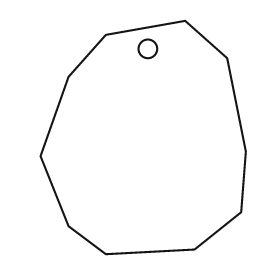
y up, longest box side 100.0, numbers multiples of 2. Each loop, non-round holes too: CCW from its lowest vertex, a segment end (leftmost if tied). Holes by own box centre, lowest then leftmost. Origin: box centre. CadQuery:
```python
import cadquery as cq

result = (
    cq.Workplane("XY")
    .moveTo(-16.0, -50.0)
    .lineTo(22.0, -48.0)
    .lineTo(42.0, -32.0)
    .lineTo(44.0, -6.0)
    .lineTo(36.0, 34.0)
    .lineTo(18.0, 50.0)
    .lineTo(-16.0, 44.0)
    .lineTo(-32.0, 26.0)
    .lineTo(-44.0, -8.0)
    .lineTo(-32.0, -38.0)
    .close()
    .moveTo(2.0, 38.0)
    .circle(4.0)
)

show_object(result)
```